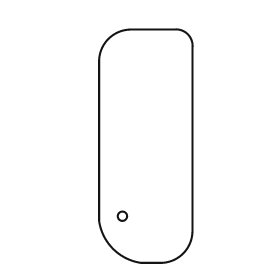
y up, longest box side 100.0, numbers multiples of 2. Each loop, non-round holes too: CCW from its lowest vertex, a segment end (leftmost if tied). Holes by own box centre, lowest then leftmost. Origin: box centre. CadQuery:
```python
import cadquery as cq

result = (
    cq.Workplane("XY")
    .moveTo(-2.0, -50.0)
    .lineTo(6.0, -50.0)
    .threePointArc((16.0, -46.0), (20.0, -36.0))
    .lineTo(20.0, 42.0)
    .threePointArc((18.0, 48.0), (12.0, 50.0))
    .lineTo(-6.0, 50.0)
    .threePointArc((-16.0, 46.0), (-20.0, 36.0))
    .lineTo(-20.0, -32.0)
    .threePointArc((-14.0, -44.0), (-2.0, -50.0))
    .close()
    .moveTo(-10.0, -30.0)
    .circle(2.0)
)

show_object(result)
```